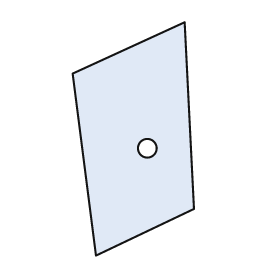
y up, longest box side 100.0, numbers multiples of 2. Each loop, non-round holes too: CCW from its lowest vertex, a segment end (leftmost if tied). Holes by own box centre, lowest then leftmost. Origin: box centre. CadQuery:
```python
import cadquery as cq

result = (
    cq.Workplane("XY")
    .moveTo(-16.0, -50.0)
    .lineTo(26.0, -30.0)
    .lineTo(22.0, 50.0)
    .lineTo(-26.0, 28.0)
    .close()
    .moveTo(6.0, -4.0)
    .circle(4.0)
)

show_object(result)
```